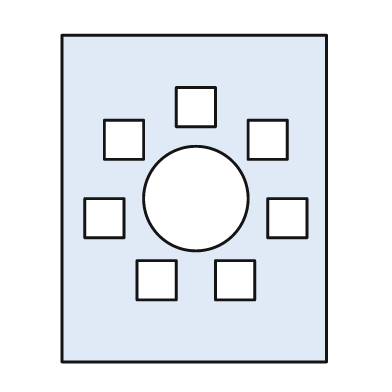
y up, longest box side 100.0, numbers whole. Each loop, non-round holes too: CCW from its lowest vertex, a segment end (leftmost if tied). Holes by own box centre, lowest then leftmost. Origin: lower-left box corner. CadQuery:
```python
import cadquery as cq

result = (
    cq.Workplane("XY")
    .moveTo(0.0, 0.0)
    .lineTo(81.0, 0.0)
    .lineTo(81.0, 100.0)
    .lineTo(0.0, 100.0)
    .close()
    .moveTo(23.0, 19.0)
    .lineTo(35.0, 19.0)
    .lineTo(35.0, 31.0)
    .lineTo(23.0, 31.0)
    .close()
    .moveTo(47.0, 19.0)
    .lineTo(59.0, 19.0)
    .lineTo(59.0, 31.0)
    .lineTo(47.0, 31.0)
    .close()
    .moveTo(7.0, 38.0)
    .lineTo(19.0, 38.0)
    .lineTo(19.0, 50.0)
    .lineTo(7.0, 50.0)
    .close()
    .moveTo(63.0, 38.0)
    .lineTo(75.0, 38.0)
    .lineTo(75.0, 50.0)
    .lineTo(63.0, 50.0)
    .close()
    .moveTo(41.0, 50.0)
    .circle(16.0)
    .moveTo(13.0, 62.0)
    .lineTo(25.0, 62.0)
    .lineTo(25.0, 74.0)
    .lineTo(13.0, 74.0)
    .close()
    .moveTo(57.0, 62.0)
    .lineTo(69.0, 62.0)
    .lineTo(69.0, 74.0)
    .lineTo(57.0, 74.0)
    .close()
    .moveTo(35.0, 72.0)
    .lineTo(47.0, 72.0)
    .lineTo(47.0, 84.0)
    .lineTo(35.0, 84.0)
    .close()
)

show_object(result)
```